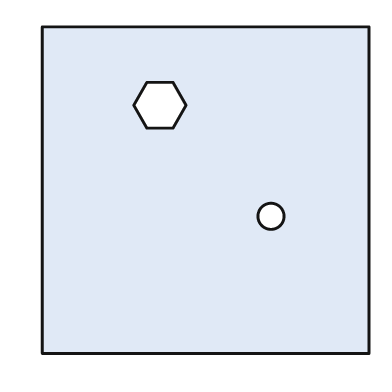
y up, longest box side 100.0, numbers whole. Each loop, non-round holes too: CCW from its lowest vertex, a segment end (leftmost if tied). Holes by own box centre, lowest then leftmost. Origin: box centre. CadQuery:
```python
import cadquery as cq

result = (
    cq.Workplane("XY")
    .moveTo(-50.0, -50.0)
    .lineTo(50.0, -50.0)
    .lineTo(50.0, 50.0)
    .lineTo(-50.0, 50.0)
    .close()
    .moveTo(20.0, -8.0)
    .circle(4.0)
    .moveTo(-18.0, 19.0)
    .lineTo(-10.0, 19.0)
    .lineTo(-6.0, 26.0)
    .lineTo(-10.0, 33.0)
    .lineTo(-18.0, 33.0)
    .lineTo(-22.0, 26.0)
    .close()
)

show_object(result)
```